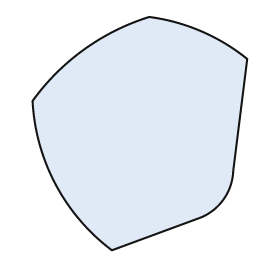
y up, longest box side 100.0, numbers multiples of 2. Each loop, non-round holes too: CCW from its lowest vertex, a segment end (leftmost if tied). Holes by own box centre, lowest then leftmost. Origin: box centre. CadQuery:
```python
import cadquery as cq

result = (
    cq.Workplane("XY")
    .moveTo(-12.0, -50.0)
    .lineTo(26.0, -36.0)
    .threePointArc((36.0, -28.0), (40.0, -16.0))
    .lineTo(46.0, 32.0)
    .threePointArc((26.0, 44.0), (4.0, 50.0))
    .threePointArc((-24.0, 36.0), (-46.0, 14.0))
    .threePointArc((-36.0, -22.0), (-12.0, -50.0))
    .close()
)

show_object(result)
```